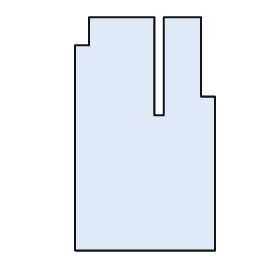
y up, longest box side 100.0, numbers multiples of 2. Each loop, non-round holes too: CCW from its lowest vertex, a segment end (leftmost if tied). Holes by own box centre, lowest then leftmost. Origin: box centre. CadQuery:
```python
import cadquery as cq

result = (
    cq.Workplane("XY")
    .moveTo(-30.0, -50.0)
    .lineTo(30.0, -50.0)
    .lineTo(30.0, 16.0)
    .lineTo(24.0, 16.0)
    .lineTo(24.0, 50.0)
    .lineTo(8.0, 50.0)
    .lineTo(8.0, 8.0)
    .lineTo(4.0, 8.0)
    .lineTo(4.0, 50.0)
    .lineTo(-24.0, 50.0)
    .lineTo(-24.0, 38.0)
    .lineTo(-30.0, 38.0)
    .close()
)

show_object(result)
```